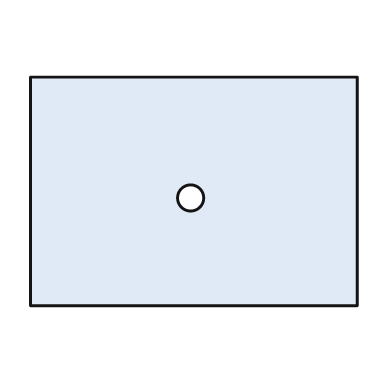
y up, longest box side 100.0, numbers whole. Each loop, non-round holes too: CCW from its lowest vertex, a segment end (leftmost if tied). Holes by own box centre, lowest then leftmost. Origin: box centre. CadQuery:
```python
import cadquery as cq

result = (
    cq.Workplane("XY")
    .moveTo(-50.0, -35.0)
    .lineTo(50.0, -35.0)
    .lineTo(50.0, 35.0)
    .lineTo(-50.0, 35.0)
    .close()
    .moveTo(-1.0, -2.0)
    .circle(4.0)
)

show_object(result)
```